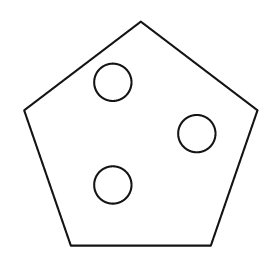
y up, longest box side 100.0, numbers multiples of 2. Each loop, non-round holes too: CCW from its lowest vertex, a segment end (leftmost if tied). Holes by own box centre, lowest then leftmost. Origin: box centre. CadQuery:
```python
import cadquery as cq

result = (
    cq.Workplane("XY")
    .moveTo(-30.0, -48.0)
    .lineTo(30.0, -48.0)
    .lineTo(50.0, 10.0)
    .lineTo(0.0, 48.0)
    .lineTo(-50.0, 10.0)
    .close()
    .moveTo(-12.0, -22.0)
    .circle(8.0)
    .moveTo(24.0, 0.0)
    .circle(8.0)
    .moveTo(-12.0, 22.0)
    .circle(8.0)
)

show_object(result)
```